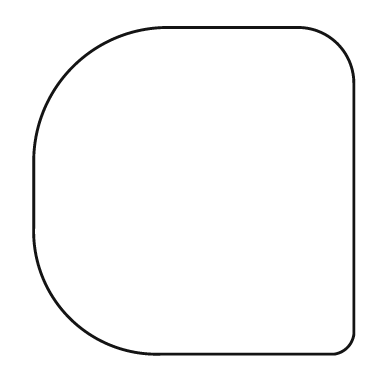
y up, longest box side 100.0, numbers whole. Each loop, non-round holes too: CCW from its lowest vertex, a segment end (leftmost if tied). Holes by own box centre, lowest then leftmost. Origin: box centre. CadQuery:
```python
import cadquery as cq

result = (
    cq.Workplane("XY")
    .moveTo(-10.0, -50.0)
    .lineTo(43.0, -50.0)
    .threePointArc((47.0, -48.0), (49.0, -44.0))
    .lineTo(49.0, 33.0)
    .threePointArc((44.0, 45.0), (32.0, 50.0))
    .lineTo(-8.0, 50.0)
    .threePointArc((-37.0, 38.0), (-49.0, 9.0))
    .lineTo(-49.0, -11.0)
    .threePointArc((-38.0, -39.0), (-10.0, -50.0))
    .close()
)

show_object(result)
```